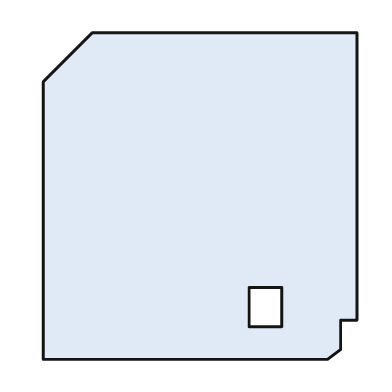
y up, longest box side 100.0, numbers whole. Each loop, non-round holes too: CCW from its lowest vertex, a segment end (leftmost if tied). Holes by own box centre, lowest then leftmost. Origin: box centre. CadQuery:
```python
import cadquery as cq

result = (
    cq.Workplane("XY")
    .moveTo(-48.0, -50.0)
    .lineTo(39.0, -50.0)
    .lineTo(43.0, -47.0)
    .lineTo(43.0, -38.0)
    .lineTo(48.0, -38.0)
    .lineTo(48.0, 50.0)
    .lineTo(-33.0, 50.0)
    .lineTo(-48.0, 35.0)
    .close()
    .moveTo(15.0, -40.0)
    .lineTo(25.0, -40.0)
    .lineTo(25.0, -28.0)
    .lineTo(15.0, -28.0)
    .close()
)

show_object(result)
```